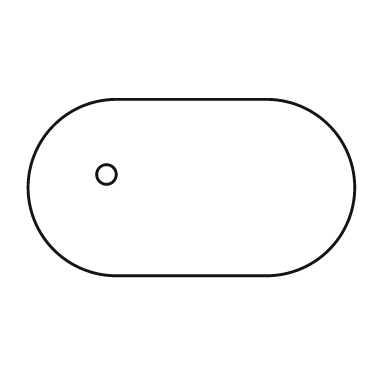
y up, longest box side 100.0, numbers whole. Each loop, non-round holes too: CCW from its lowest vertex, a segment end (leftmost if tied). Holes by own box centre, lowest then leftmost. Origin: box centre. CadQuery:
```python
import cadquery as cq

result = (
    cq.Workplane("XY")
    .moveTo(-23.0, -27.0)
    .lineTo(23.0, -27.0)
    .threePointArc((50.0, 0.0), (23.0, 27.0))
    .lineTo(-23.0, 27.0)
    .threePointArc((-50.0, 0.0), (-23.0, -27.0))
    .close()
    .moveTo(-26.0, 4.0)
    .circle(3.0)
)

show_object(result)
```